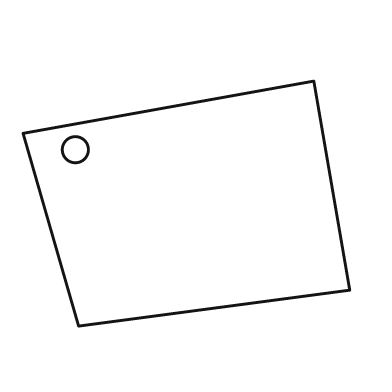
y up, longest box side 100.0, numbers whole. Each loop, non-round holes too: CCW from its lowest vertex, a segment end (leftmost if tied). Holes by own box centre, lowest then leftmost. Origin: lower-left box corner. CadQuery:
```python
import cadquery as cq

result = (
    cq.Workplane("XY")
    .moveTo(17.0, 0.0)
    .lineTo(100.0, 11.0)
    .lineTo(89.0, 75.0)
    .lineTo(0.0, 59.0)
    .close()
    .moveTo(16.0, 54.0)
    .circle(4.0)
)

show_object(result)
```